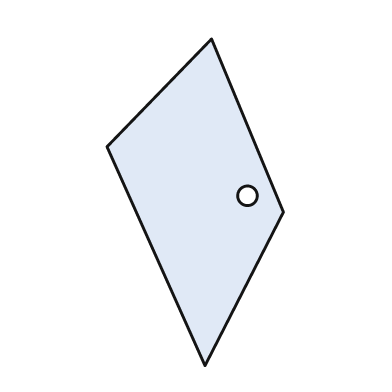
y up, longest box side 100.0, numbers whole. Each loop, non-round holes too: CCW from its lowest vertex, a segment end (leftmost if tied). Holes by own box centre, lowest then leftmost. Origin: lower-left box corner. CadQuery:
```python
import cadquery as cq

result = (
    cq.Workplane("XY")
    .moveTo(30.0, 0.0)
    .lineTo(54.0, 47.0)
    .lineTo(32.0, 100.0)
    .lineTo(0.0, 67.0)
    .close()
    .moveTo(43.0, 52.0)
    .circle(3.0)
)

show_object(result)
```